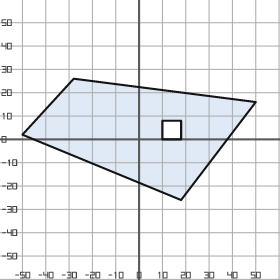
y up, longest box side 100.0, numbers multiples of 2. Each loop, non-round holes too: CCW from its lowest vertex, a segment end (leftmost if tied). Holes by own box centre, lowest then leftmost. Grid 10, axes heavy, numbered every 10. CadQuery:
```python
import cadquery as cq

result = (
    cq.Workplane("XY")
    .moveTo(18.0, -26.0)
    .lineTo(50.0, 16.0)
    .lineTo(-28.0, 26.0)
    .lineTo(-50.0, 2.0)
    .close()
    .moveTo(10.0, 0.0)
    .lineTo(18.0, 0.0)
    .lineTo(18.0, 8.0)
    .lineTo(10.0, 8.0)
    .close()
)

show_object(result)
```